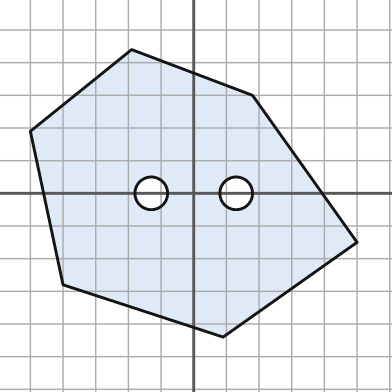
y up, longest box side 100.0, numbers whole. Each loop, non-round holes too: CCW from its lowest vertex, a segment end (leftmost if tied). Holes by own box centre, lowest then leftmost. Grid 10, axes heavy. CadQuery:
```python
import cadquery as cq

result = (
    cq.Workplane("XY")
    .moveTo(9.0, -44.0)
    .lineTo(50.0, -15.0)
    .lineTo(18.0, 30.0)
    .lineTo(-19.0, 44.0)
    .lineTo(-50.0, 19.0)
    .lineTo(-40.0, -28.0)
    .close()
    .moveTo(-13.0, 0.0)
    .circle(5.0)
    .moveTo(13.0, 0.0)
    .circle(5.0)
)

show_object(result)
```